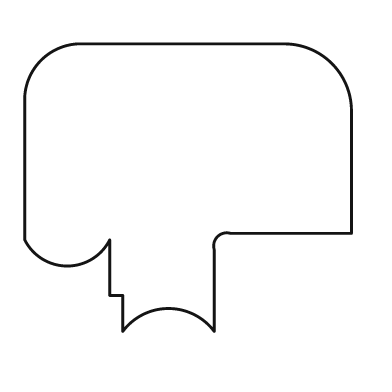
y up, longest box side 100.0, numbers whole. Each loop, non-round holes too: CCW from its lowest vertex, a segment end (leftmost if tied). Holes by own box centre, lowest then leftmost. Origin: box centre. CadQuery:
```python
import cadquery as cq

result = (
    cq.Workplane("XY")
    .moveTo(-20.0, -44.0)
    .threePointArc((-6.0, -37.0), (8.0, -44.0))
    .lineTo(8.0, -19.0)
    .threePointArc((9.0, -15.0), (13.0, -14.0))
    .lineTo(50.0, -14.0)
    .lineTo(50.0, 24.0)
    .threePointArc((44.0, 38.0), (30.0, 44.0))
    .lineTo(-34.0, 44.0)
    .threePointArc((-45.0, 39.0), (-50.0, 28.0))
    .lineTo(-50.0, -16.0)
    .threePointArc((-37.0, -24.0), (-24.0, -16.0))
    .lineTo(-24.0, -33.0)
    .lineTo(-20.0, -33.0)
    .close()
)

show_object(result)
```